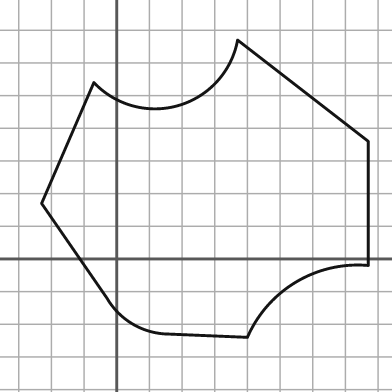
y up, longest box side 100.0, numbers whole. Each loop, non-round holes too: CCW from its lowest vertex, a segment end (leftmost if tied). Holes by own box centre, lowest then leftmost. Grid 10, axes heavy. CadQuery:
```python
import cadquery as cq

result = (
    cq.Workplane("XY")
    .moveTo(40.0, -24.0)
    .threePointArc((55.0, -7.0), (77.0, -2.0))
    .lineTo(77.0, 36.0)
    .lineTo(37.0, 67.0)
    .threePointArc((19.0, 47.0), (-7.0, 54.0))
    .lineTo(-23.0, 17.0)
    .lineTo(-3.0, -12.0)
    .threePointArc((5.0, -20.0), (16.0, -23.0))
    .close()
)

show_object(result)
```